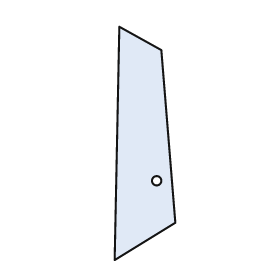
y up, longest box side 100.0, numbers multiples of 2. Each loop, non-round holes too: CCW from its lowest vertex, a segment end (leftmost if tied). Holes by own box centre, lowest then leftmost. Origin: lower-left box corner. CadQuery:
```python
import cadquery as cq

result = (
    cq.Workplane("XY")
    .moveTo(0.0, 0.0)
    .lineTo(26.0, 16.0)
    .lineTo(20.0, 90.0)
    .lineTo(2.0, 100.0)
    .close()
    .moveTo(18.0, 34.0)
    .circle(2.0)
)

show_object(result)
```